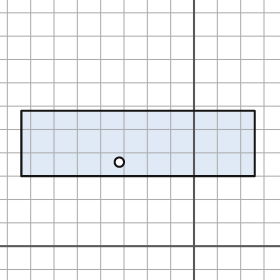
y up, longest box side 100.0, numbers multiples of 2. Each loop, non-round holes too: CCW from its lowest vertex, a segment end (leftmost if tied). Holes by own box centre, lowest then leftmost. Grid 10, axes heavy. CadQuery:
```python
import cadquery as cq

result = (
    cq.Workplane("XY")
    .moveTo(-74.0, 30.0)
    .lineTo(26.0, 30.0)
    .lineTo(26.0, 58.0)
    .lineTo(-74.0, 58.0)
    .close()
    .moveTo(-32.0, 36.0)
    .circle(2.0)
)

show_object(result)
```